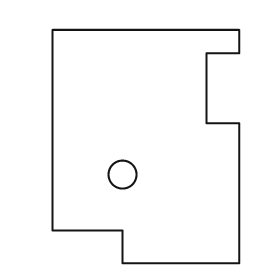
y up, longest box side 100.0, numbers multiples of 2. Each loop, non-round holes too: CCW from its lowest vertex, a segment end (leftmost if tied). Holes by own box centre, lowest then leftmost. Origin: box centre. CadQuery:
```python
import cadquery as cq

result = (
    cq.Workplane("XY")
    .moveTo(-10.0, -50.0)
    .lineTo(40.0, -50.0)
    .lineTo(40.0, 10.0)
    .lineTo(26.0, 10.0)
    .lineTo(26.0, 40.0)
    .lineTo(40.0, 40.0)
    .lineTo(40.0, 50.0)
    .lineTo(-40.0, 50.0)
    .lineTo(-40.0, -36.0)
    .lineTo(-10.0, -36.0)
    .close()
    .moveTo(-10.0, -12.0)
    .circle(6.0)
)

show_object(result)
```